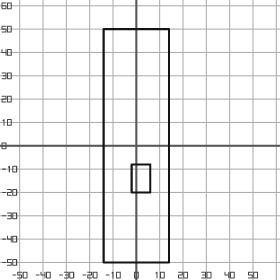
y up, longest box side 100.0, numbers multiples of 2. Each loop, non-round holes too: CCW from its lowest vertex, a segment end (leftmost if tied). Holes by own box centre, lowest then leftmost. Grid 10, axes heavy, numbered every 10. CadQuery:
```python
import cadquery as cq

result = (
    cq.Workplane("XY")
    .moveTo(-14.0, -50.0)
    .lineTo(14.0, -50.0)
    .lineTo(14.0, 50.0)
    .lineTo(-14.0, 50.0)
    .close()
    .moveTo(-2.0, -20.0)
    .lineTo(6.0, -20.0)
    .lineTo(6.0, -8.0)
    .lineTo(-2.0, -8.0)
    .close()
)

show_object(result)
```